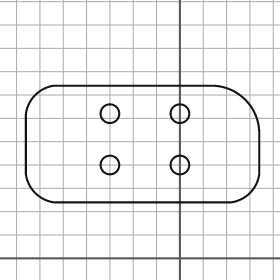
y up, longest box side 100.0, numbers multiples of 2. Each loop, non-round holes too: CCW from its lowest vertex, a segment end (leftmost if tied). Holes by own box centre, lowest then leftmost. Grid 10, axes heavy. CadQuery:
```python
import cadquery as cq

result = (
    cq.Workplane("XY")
    .moveTo(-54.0, 24.0)
    .lineTo(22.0, 24.0)
    .threePointArc((30.0, 28.0), (34.0, 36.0))
    .lineTo(34.0, 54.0)
    .threePointArc((28.0, 68.0), (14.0, 74.0))
    .lineTo(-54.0, 74.0)
    .threePointArc((-62.0, 70.0), (-66.0, 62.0))
    .lineTo(-66.0, 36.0)
    .threePointArc((-62.0, 28.0), (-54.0, 24.0))
    .close()
    .moveTo(-30.0, 40.0)
    .circle(4.0)
    .moveTo(0.0, 40.0)
    .circle(4.0)
    .moveTo(-30.0, 62.0)
    .circle(4.0)
    .moveTo(0.0, 62.0)
    .circle(4.0)
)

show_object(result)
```